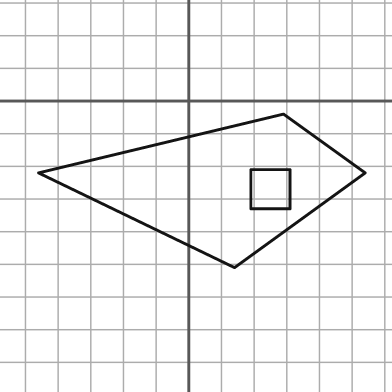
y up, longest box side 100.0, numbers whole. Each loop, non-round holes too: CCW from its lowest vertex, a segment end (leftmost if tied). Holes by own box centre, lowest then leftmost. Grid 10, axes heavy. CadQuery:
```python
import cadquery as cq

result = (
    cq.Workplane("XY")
    .moveTo(14.0, -51.0)
    .lineTo(54.0, -22.0)
    .lineTo(29.0, -4.0)
    .lineTo(-46.0, -22.0)
    .close()
    .moveTo(19.0, -33.0)
    .lineTo(31.0, -33.0)
    .lineTo(31.0, -21.0)
    .lineTo(19.0, -21.0)
    .close()
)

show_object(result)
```